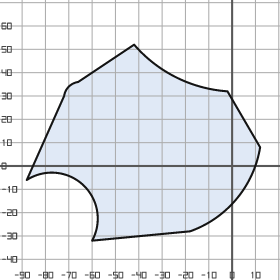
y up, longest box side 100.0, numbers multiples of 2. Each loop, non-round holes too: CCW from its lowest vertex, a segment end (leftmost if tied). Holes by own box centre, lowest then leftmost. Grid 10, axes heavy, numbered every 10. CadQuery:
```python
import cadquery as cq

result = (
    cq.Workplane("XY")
    .moveTo(-60.0, -32.0)
    .lineTo(-18.0, -28.0)
    .threePointArc((2.0, -14.0), (12.0, 8.0))
    .lineTo(-2.0, 32.0)
    .threePointArc((-24.0, 38.0), (-42.0, 52.0))
    .lineTo(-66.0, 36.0)
    .threePointArc((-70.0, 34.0), (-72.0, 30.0))
    .lineTo(-88.0, -6.0)
    .threePointArc((-64.0, -8.0), (-60.0, -32.0))
    .close()
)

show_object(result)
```